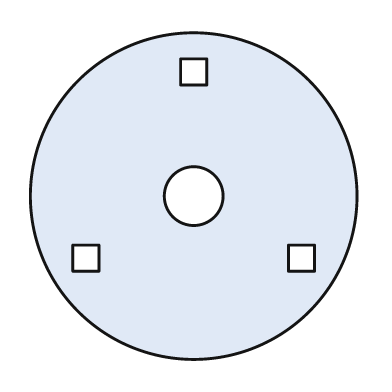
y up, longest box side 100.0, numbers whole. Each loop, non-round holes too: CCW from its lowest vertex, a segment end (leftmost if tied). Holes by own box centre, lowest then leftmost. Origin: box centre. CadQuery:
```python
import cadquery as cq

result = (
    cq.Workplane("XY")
    .moveTo(0.0, 0.0)
    .circle(50.0)
    .moveTo(-37.0, -23.0)
    .lineTo(-29.0, -23.0)
    .lineTo(-29.0, -15.0)
    .lineTo(-37.0, -15.0)
    .close()
    .moveTo(29.0, -23.0)
    .lineTo(37.0, -23.0)
    .lineTo(37.0, -15.0)
    .lineTo(29.0, -15.0)
    .close()
    .moveTo(0.0, 0.0)
    .circle(9.0)
    .moveTo(-4.0, 34.0)
    .lineTo(4.0, 34.0)
    .lineTo(4.0, 42.0)
    .lineTo(-4.0, 42.0)
    .close()
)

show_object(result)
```